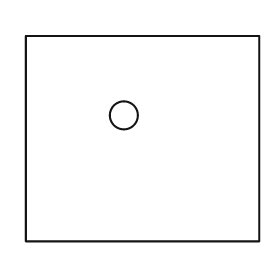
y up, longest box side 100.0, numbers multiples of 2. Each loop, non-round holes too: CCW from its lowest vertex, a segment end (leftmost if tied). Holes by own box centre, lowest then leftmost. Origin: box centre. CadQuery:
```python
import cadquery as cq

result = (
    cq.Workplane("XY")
    .moveTo(-50.0, -44.0)
    .lineTo(50.0, -44.0)
    .lineTo(50.0, 44.0)
    .lineTo(-50.0, 44.0)
    .close()
    .moveTo(-8.0, 10.0)
    .circle(6.0)
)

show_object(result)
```